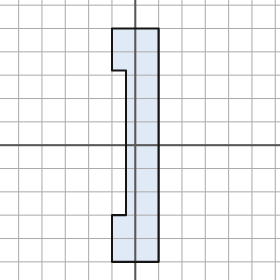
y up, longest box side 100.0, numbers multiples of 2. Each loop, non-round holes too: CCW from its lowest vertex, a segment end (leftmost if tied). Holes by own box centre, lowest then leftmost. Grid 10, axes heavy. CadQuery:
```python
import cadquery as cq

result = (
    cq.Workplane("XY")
    .moveTo(-10.0, -50.0)
    .lineTo(10.0, -50.0)
    .lineTo(10.0, 50.0)
    .lineTo(-10.0, 50.0)
    .lineTo(-10.0, 32.0)
    .lineTo(-4.0, 32.0)
    .lineTo(-4.0, -30.0)
    .lineTo(-10.0, -30.0)
    .close()
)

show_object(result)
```